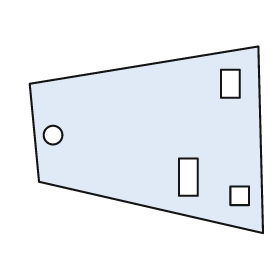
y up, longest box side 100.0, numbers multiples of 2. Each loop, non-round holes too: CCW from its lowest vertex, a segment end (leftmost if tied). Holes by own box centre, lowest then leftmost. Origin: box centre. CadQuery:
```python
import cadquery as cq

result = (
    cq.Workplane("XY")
    .moveTo(50.0, -40.0)
    .lineTo(48.0, 40.0)
    .lineTo(-50.0, 24.0)
    .lineTo(-46.0, -18.0)
    .close()
    .moveTo(36.0, -28.0)
    .lineTo(44.0, -28.0)
    .lineTo(44.0, -20.0)
    .lineTo(36.0, -20.0)
    .close()
    .moveTo(14.0, -24.0)
    .lineTo(22.0, -24.0)
    .lineTo(22.0, -8.0)
    .lineTo(14.0, -8.0)
    .close()
    .moveTo(-40.0, 2.0)
    .circle(4.0)
    .moveTo(32.0, 18.0)
    .lineTo(40.0, 18.0)
    .lineTo(40.0, 30.0)
    .lineTo(32.0, 30.0)
    .close()
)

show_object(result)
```